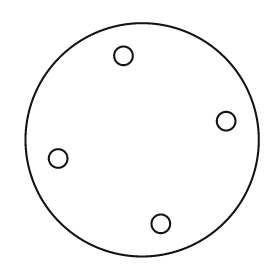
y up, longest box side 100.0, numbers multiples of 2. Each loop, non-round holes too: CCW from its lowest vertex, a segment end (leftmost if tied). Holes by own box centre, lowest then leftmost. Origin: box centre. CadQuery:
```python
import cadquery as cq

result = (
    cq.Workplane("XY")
    .moveTo(0.0, 0.0)
    .circle(50.0)
    .moveTo(8.0, -36.0)
    .circle(4.0)
    .moveTo(-36.0, -8.0)
    .circle(4.0)
    .moveTo(36.0, 8.0)
    .circle(4.0)
    .moveTo(-8.0, 36.0)
    .circle(4.0)
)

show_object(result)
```